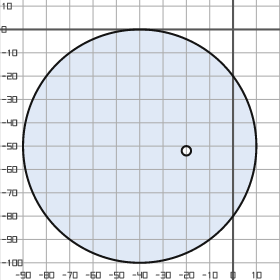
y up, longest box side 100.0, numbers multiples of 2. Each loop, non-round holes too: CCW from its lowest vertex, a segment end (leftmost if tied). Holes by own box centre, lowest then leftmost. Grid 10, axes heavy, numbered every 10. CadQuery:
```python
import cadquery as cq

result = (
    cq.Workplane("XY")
    .moveTo(-40.0, -50.0)
    .circle(50.0)
    .moveTo(-20.0, -52.0)
    .circle(2.0)
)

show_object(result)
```